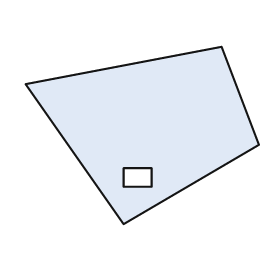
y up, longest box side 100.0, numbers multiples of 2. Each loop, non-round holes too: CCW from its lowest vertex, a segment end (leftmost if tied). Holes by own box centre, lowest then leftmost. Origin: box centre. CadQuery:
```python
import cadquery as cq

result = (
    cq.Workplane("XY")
    .moveTo(-8.0, -38.0)
    .lineTo(50.0, -4.0)
    .lineTo(34.0, 38.0)
    .lineTo(-50.0, 22.0)
    .close()
    .moveTo(-8.0, -22.0)
    .lineTo(4.0, -22.0)
    .lineTo(4.0, -14.0)
    .lineTo(-8.0, -14.0)
    .close()
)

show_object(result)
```